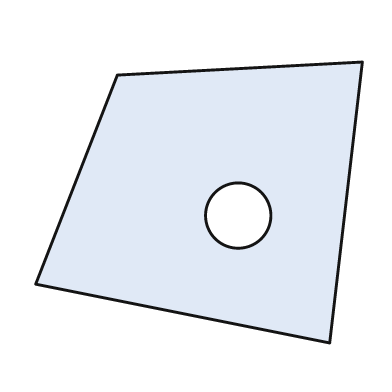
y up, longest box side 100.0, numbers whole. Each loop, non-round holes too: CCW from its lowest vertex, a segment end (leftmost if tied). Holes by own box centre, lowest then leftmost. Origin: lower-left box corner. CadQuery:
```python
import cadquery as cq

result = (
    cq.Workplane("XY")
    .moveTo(90.0, 0.0)
    .lineTo(100.0, 86.0)
    .lineTo(25.0, 82.0)
    .lineTo(0.0, 18.0)
    .close()
    .moveTo(62.0, 39.0)
    .circle(10.0)
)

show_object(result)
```